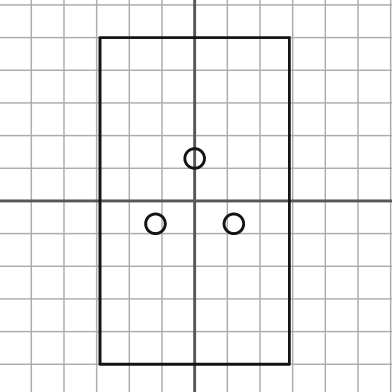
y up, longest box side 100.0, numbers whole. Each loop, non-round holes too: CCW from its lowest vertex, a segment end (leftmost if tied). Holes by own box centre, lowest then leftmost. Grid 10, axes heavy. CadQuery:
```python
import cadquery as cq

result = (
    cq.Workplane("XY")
    .moveTo(-29.0, -50.0)
    .lineTo(29.0, -50.0)
    .lineTo(29.0, 50.0)
    .lineTo(-29.0, 50.0)
    .close()
    .moveTo(-12.0, -7.0)
    .circle(3.0)
    .moveTo(12.0, -7.0)
    .circle(3.0)
    .moveTo(0.0, 13.0)
    .circle(3.0)
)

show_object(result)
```